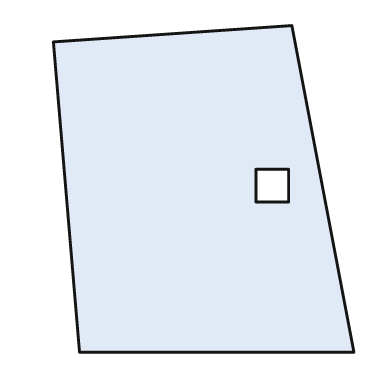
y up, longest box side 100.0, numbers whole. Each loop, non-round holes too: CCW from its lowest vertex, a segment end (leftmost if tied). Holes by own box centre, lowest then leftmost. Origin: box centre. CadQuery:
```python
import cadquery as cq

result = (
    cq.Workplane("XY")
    .moveTo(-38.0, -50.0)
    .lineTo(46.0, -50.0)
    .lineTo(27.0, 50.0)
    .lineTo(-46.0, 45.0)
    .close()
    .moveTo(16.0, -4.0)
    .lineTo(26.0, -4.0)
    .lineTo(26.0, 6.0)
    .lineTo(16.0, 6.0)
    .close()
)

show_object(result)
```